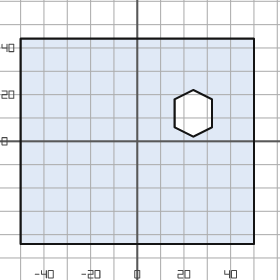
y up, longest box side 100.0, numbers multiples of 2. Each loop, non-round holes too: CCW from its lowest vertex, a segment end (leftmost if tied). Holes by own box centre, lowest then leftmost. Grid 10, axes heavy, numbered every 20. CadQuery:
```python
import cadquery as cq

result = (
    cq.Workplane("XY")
    .moveTo(-50.0, -44.0)
    .lineTo(50.0, -44.0)
    .lineTo(50.0, 44.0)
    .lineTo(-50.0, 44.0)
    .close()
    .moveTo(24.0, 2.0)
    .lineTo(32.0, 6.0)
    .lineTo(32.0, 18.0)
    .lineTo(24.0, 22.0)
    .lineTo(16.0, 18.0)
    .lineTo(16.0, 6.0)
    .close()
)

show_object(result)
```